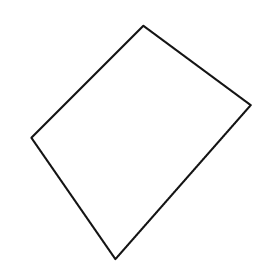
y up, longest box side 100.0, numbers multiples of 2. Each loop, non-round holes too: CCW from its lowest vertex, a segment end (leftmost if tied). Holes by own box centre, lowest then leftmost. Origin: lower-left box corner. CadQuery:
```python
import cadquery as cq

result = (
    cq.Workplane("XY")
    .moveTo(36.0, 0.0)
    .lineTo(94.0, 66.0)
    .lineTo(48.0, 100.0)
    .lineTo(0.0, 52.0)
    .close()
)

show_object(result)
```